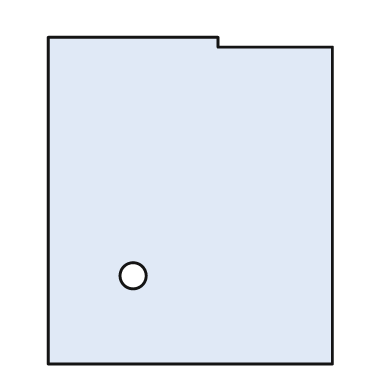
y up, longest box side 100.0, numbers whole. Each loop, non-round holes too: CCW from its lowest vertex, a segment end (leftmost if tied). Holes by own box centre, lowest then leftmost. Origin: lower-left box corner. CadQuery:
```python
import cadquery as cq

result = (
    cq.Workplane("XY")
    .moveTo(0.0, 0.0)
    .lineTo(87.0, 0.0)
    .lineTo(87.0, 97.0)
    .lineTo(52.0, 97.0)
    .lineTo(52.0, 100.0)
    .lineTo(0.0, 100.0)
    .close()
    .moveTo(26.0, 27.0)
    .circle(4.0)
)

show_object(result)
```